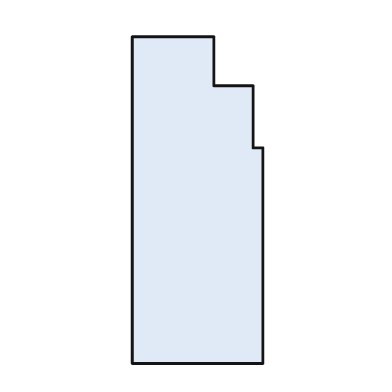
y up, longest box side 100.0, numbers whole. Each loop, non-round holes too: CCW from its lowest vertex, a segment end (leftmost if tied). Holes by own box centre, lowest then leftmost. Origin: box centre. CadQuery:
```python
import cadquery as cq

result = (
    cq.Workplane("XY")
    .moveTo(-20.0, -50.0)
    .lineTo(20.0, -50.0)
    .lineTo(20.0, 16.0)
    .lineTo(17.0, 16.0)
    .lineTo(17.0, 35.0)
    .lineTo(5.0, 35.0)
    .lineTo(5.0, 50.0)
    .lineTo(-20.0, 50.0)
    .close()
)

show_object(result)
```